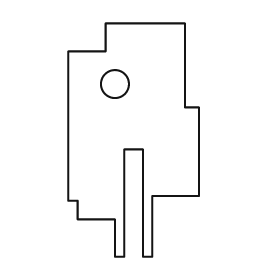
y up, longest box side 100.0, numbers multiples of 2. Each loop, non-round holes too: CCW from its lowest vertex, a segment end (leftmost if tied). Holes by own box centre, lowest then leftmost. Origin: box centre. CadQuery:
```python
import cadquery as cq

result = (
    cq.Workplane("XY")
    .moveTo(-8.0, -50.0)
    .lineTo(-4.0, -50.0)
    .lineTo(-4.0, -4.0)
    .lineTo(4.0, -4.0)
    .lineTo(4.0, -50.0)
    .lineTo(8.0, -50.0)
    .lineTo(8.0, -24.0)
    .lineTo(28.0, -24.0)
    .lineTo(28.0, 14.0)
    .lineTo(22.0, 14.0)
    .lineTo(22.0, 50.0)
    .lineTo(-12.0, 50.0)
    .lineTo(-12.0, 38.0)
    .lineTo(-28.0, 38.0)
    .lineTo(-28.0, -26.0)
    .lineTo(-24.0, -26.0)
    .lineTo(-24.0, -34.0)
    .lineTo(-8.0, -34.0)
    .close()
    .moveTo(-8.0, 24.0)
    .circle(6.0)
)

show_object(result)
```